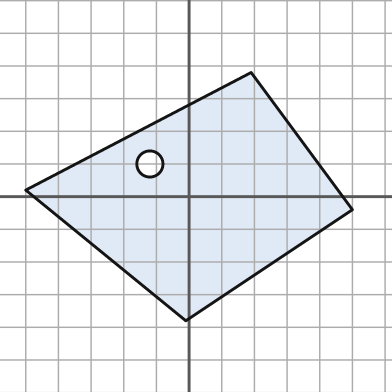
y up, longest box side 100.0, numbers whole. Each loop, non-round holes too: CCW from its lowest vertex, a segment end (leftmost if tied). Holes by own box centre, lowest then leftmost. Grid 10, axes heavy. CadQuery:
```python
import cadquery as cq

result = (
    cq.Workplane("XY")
    .moveTo(-1.0, -38.0)
    .lineTo(50.0, -4.0)
    .lineTo(19.0, 38.0)
    .lineTo(-50.0, 2.0)
    .close()
    .moveTo(-12.0, 10.0)
    .circle(4.0)
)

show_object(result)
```